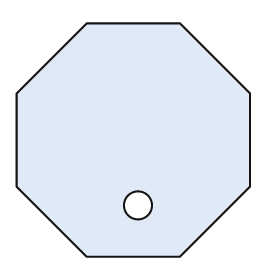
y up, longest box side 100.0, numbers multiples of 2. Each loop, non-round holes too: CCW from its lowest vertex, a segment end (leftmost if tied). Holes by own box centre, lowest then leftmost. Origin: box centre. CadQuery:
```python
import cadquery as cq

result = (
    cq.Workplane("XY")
    .moveTo(-20.0, -50.0)
    .lineTo(20.0, -50.0)
    .lineTo(50.0, -20.0)
    .lineTo(50.0, 20.0)
    .lineTo(20.0, 50.0)
    .lineTo(-20.0, 50.0)
    .lineTo(-50.0, 20.0)
    .lineTo(-50.0, -20.0)
    .close()
    .moveTo(2.0, -28.0)
    .circle(6.0)
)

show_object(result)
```